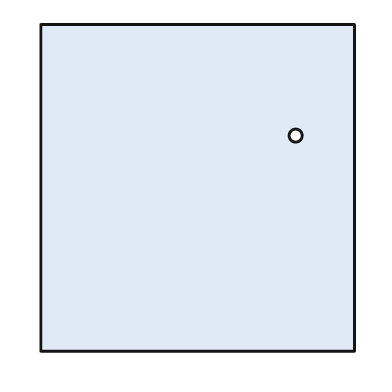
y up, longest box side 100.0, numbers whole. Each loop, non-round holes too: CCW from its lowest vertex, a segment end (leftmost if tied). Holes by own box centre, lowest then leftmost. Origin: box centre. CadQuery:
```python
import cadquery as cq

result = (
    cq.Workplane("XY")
    .moveTo(-48.0, -50.0)
    .lineTo(48.0, -50.0)
    .lineTo(48.0, 50.0)
    .lineTo(-48.0, 50.0)
    .close()
    .moveTo(30.0, 16.0)
    .circle(2.0)
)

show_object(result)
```